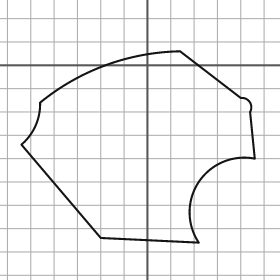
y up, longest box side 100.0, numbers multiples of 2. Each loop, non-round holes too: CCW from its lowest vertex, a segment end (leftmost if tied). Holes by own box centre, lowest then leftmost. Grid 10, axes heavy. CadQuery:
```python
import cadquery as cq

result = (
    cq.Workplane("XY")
    .moveTo(22.0, -76.0)
    .threePointArc((22.0, -50.0), (46.0, -40.0))
    .lineTo(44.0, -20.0)
    .threePointArc((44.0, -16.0), (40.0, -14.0))
    .lineTo(14.0, 6.0)
    .threePointArc((-18.0, 0.0), (-46.0, -16.0))
    .threePointArc((-48.0, -26.0), (-54.0, -34.0))
    .lineTo(-20.0, -74.0)
    .close()
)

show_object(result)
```